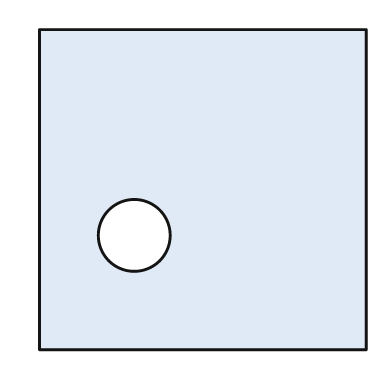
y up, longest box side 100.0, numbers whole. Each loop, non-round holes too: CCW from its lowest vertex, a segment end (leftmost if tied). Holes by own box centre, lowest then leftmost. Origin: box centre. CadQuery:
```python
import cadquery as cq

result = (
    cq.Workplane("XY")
    .moveTo(-50.0, -49.0)
    .lineTo(50.0, -49.0)
    .lineTo(50.0, 49.0)
    .lineTo(-50.0, 49.0)
    .close()
    .moveTo(-21.0, -14.0)
    .circle(11.0)
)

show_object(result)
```